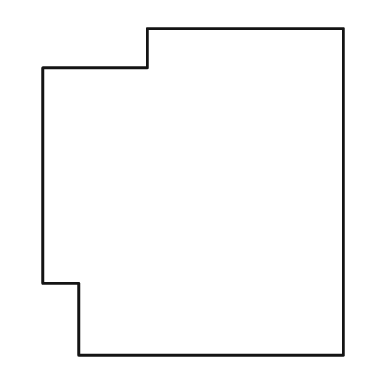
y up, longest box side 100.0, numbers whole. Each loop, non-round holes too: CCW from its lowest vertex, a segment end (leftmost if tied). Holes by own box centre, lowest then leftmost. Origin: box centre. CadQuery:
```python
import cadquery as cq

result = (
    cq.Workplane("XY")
    .moveTo(-35.0, -50.0)
    .lineTo(46.0, -50.0)
    .lineTo(46.0, 50.0)
    .lineTo(-14.0, 50.0)
    .lineTo(-14.0, 38.0)
    .lineTo(-46.0, 38.0)
    .lineTo(-46.0, -28.0)
    .lineTo(-35.0, -28.0)
    .close()
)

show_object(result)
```